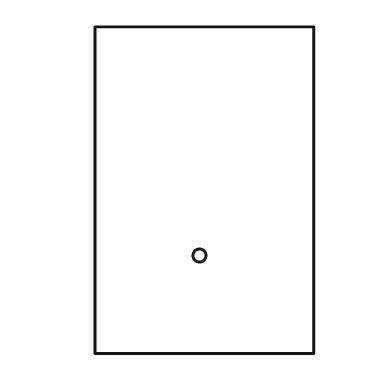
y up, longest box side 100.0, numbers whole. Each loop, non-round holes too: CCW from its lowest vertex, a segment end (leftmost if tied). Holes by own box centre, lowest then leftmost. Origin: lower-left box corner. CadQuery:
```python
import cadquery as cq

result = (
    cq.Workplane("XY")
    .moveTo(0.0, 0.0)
    .lineTo(67.0, 0.0)
    .lineTo(67.0, 100.0)
    .lineTo(0.0, 100.0)
    .close()
    .moveTo(32.0, 30.0)
    .circle(2.0)
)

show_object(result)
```